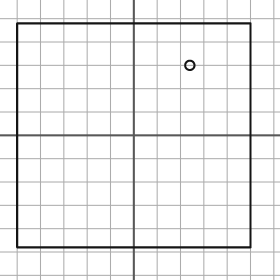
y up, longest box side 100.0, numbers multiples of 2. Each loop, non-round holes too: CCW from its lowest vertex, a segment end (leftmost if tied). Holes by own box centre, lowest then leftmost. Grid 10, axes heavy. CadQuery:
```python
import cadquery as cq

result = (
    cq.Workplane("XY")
    .moveTo(-50.0, -48.0)
    .lineTo(50.0, -48.0)
    .lineTo(50.0, 48.0)
    .lineTo(-50.0, 48.0)
    .close()
    .moveTo(24.0, 30.0)
    .circle(2.0)
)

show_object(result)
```